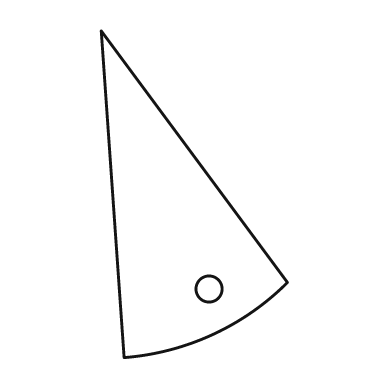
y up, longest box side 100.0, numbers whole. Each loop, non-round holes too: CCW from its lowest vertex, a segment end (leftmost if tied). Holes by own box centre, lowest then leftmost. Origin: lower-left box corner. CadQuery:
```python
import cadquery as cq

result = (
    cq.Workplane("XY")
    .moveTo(7.0, 0.0)
    .threePointArc((34.0, 7.0), (57.0, 23.0))
    .lineTo(0.0, 100.0)
    .close()
    .moveTo(33.0, 21.0)
    .circle(4.0)
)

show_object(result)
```